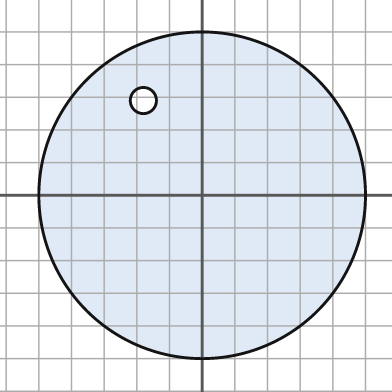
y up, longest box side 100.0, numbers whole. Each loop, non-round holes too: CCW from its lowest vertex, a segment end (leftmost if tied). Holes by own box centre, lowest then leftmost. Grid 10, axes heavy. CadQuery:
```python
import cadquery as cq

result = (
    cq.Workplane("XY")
    .moveTo(0.0, 0.0)
    .circle(50.0)
    .moveTo(-18.0, 29.0)
    .circle(4.0)
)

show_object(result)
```